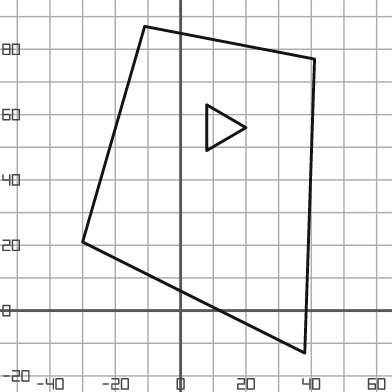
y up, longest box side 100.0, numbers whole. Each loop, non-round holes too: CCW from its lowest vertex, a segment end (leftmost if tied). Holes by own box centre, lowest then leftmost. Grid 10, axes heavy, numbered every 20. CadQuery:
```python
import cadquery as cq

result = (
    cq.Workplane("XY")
    .moveTo(38.0, -13.0)
    .lineTo(41.0, 77.0)
    .lineTo(-11.0, 87.0)
    .lineTo(-30.0, 21.0)
    .close()
    .moveTo(8.0, 49.0)
    .lineTo(20.0, 56.0)
    .lineTo(8.0, 63.0)
    .close()
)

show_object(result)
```